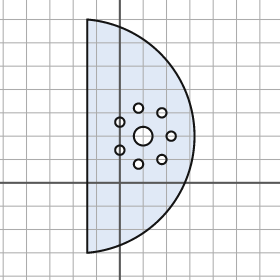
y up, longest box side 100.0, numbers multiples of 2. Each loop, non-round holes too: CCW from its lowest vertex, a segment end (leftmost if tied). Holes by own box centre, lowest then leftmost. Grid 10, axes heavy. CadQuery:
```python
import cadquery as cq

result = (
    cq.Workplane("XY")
    .moveTo(-14.0, -30.0)
    .threePointArc((32.0, 20.0), (-14.0, 70.0))
    .close()
    .moveTo(8.0, 8.0)
    .circle(2.0)
    .moveTo(18.0, 10.0)
    .circle(2.0)
    .moveTo(0.0, 14.0)
    .circle(2.0)
    .moveTo(10.0, 20.0)
    .circle(4.0)
    .moveTo(22.0, 20.0)
    .circle(2.0)
    .moveTo(0.0, 26.0)
    .circle(2.0)
    .moveTo(18.0, 30.0)
    .circle(2.0)
    .moveTo(8.0, 32.0)
    .circle(2.0)
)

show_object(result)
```